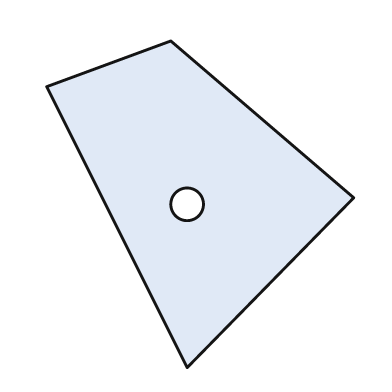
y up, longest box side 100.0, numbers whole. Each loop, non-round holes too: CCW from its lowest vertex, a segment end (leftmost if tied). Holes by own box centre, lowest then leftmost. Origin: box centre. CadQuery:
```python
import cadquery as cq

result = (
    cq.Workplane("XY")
    .moveTo(-4.0, -50.0)
    .lineTo(47.0, 2.0)
    .lineTo(-9.0, 50.0)
    .lineTo(-47.0, 36.0)
    .close()
    .moveTo(-4.0, 0.0)
    .circle(5.0)
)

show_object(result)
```